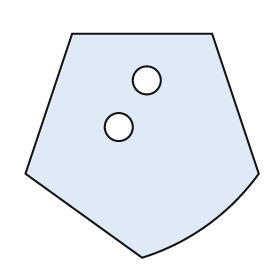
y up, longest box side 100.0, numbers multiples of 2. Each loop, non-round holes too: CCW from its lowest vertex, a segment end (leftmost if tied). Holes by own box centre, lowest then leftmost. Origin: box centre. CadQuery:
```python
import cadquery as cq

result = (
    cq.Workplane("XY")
    .moveTo(0.0, -48.0)
    .threePointArc((28.0, -34.0), (50.0, -12.0))
    .lineTo(30.0, 48.0)
    .lineTo(-30.0, 48.0)
    .lineTo(-50.0, -12.0)
    .close()
    .moveTo(-10.0, 8.0)
    .circle(6.0)
    .moveTo(2.0, 28.0)
    .circle(6.0)
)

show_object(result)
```